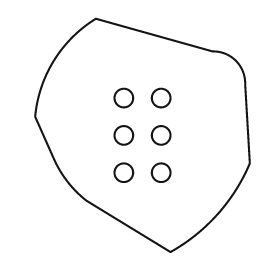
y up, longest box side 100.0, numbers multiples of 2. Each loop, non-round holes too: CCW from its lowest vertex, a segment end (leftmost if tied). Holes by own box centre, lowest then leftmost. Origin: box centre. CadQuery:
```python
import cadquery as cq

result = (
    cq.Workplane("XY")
    .moveTo(12.0, -50.0)
    .threePointArc((32.0, -34.0), (46.0, -12.0))
    .lineTo(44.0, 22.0)
    .threePointArc((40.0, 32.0), (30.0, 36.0))
    .lineTo(-20.0, 50.0)
    .threePointArc((-38.0, 32.0), (-46.0, 8.0))
    .lineTo(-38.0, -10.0)
    .threePointArc((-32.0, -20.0), (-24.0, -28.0))
    .close()
    .moveTo(-8.0, -16.0)
    .circle(4.0)
    .moveTo(8.0, -16.0)
    .circle(4.0)
    .moveTo(-8.0, 0.0)
    .circle(4.0)
    .moveTo(8.0, 0.0)
    .circle(4.0)
    .moveTo(-8.0, 16.0)
    .circle(4.0)
    .moveTo(8.0, 16.0)
    .circle(4.0)
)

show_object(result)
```